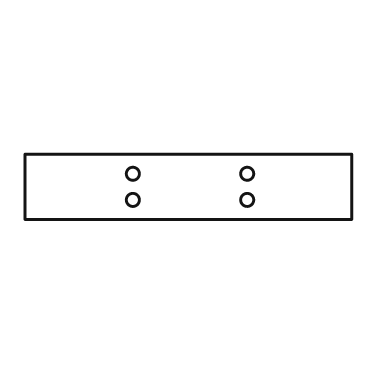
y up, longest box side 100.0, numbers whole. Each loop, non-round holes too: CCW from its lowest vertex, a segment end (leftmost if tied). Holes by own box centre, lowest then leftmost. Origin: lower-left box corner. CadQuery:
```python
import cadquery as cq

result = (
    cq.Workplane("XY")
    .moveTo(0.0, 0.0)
    .lineTo(100.0, 0.0)
    .lineTo(100.0, 20.0)
    .lineTo(0.0, 20.0)
    .close()
    .moveTo(33.0, 6.0)
    .circle(2.0)
    .moveTo(68.0, 6.0)
    .circle(2.0)
    .moveTo(33.0, 14.0)
    .circle(2.0)
    .moveTo(68.0, 14.0)
    .circle(2.0)
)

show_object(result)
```